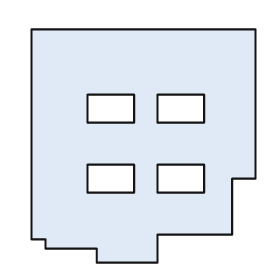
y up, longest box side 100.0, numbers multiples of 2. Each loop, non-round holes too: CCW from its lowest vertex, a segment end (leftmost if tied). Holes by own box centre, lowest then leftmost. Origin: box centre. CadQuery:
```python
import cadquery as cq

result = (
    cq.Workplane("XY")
    .moveTo(-20.0, -50.0)
    .lineTo(6.0, -50.0)
    .lineTo(6.0, -38.0)
    .lineTo(38.0, -38.0)
    .lineTo(38.0, -14.0)
    .lineTo(48.0, -14.0)
    .lineTo(48.0, 50.0)
    .lineTo(-48.0, 50.0)
    .lineTo(-48.0, -40.0)
    .lineTo(-42.0, -40.0)
    .lineTo(-42.0, -44.0)
    .lineTo(-20.0, -44.0)
    .close()
    .moveTo(-24.0, -20.0)
    .lineTo(-4.0, -20.0)
    .lineTo(-4.0, -8.0)
    .lineTo(-24.0, -8.0)
    .close()
    .moveTo(6.0, -20.0)
    .lineTo(26.0, -20.0)
    .lineTo(26.0, -8.0)
    .lineTo(6.0, -8.0)
    .close()
    .moveTo(-24.0, 10.0)
    .lineTo(-4.0, 10.0)
    .lineTo(-4.0, 22.0)
    .lineTo(-24.0, 22.0)
    .close()
    .moveTo(6.0, 10.0)
    .lineTo(26.0, 10.0)
    .lineTo(26.0, 22.0)
    .lineTo(6.0, 22.0)
    .close()
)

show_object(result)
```